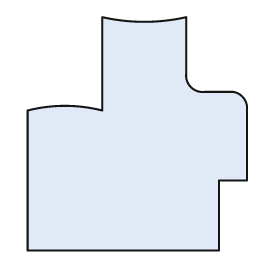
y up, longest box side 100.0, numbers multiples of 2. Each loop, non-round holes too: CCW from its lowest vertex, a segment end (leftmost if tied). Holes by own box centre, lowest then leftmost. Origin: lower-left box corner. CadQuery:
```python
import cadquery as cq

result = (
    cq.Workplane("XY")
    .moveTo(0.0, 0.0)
    .lineTo(82.0, 0.0)
    .lineTo(82.0, 30.0)
    .lineTo(94.0, 30.0)
    .lineTo(94.0, 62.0)
    .threePointArc((92.0, 66.0), (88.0, 68.0))
    .lineTo(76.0, 68.0)
    .threePointArc((70.0, 70.0), (68.0, 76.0))
    .lineTo(68.0, 100.0)
    .threePointArc((50.0, 98.0), (32.0, 100.0))
    .lineTo(32.0, 60.0)
    .threePointArc((16.0, 62.0), (0.0, 60.0))
    .close()
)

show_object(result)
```